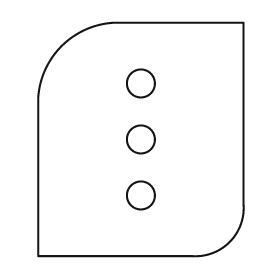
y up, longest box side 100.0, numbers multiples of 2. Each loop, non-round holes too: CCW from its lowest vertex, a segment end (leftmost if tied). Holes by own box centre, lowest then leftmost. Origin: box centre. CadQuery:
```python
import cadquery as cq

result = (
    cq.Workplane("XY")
    .moveTo(-44.0, -50.0)
    .lineTo(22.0, -50.0)
    .threePointArc((38.0, -44.0), (44.0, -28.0))
    .lineTo(44.0, 50.0)
    .lineTo(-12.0, 50.0)
    .threePointArc((-34.0, 40.0), (-44.0, 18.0))
    .close()
    .moveTo(0.0, -24.0)
    .circle(6.0)
    .moveTo(0.0, 0.0)
    .circle(6.0)
    .moveTo(0.0, 24.0)
    .circle(6.0)
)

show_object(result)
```